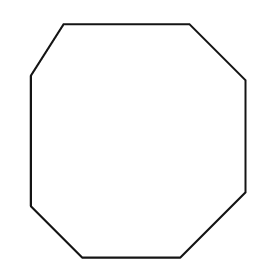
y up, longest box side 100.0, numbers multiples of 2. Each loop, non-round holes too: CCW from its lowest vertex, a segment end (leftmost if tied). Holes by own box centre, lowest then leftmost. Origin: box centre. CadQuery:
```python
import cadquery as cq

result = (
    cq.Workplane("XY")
    .moveTo(-24.0, -50.0)
    .lineTo(18.0, -50.0)
    .lineTo(46.0, -22.0)
    .lineTo(46.0, 26.0)
    .lineTo(22.0, 50.0)
    .lineTo(-32.0, 50.0)
    .lineTo(-46.0, 28.0)
    .lineTo(-46.0, -28.0)
    .close()
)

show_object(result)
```